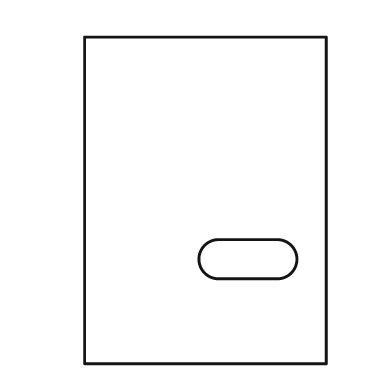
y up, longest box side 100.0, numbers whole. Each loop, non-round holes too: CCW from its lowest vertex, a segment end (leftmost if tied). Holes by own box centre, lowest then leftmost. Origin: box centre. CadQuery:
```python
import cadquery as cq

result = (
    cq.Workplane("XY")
    .moveTo(-37.0, -50.0)
    .lineTo(37.0, -50.0)
    .lineTo(37.0, 50.0)
    .lineTo(-37.0, 50.0)
    .close()
    .moveTo(4.0, -24.0)
    .lineTo(22.0, -24.0)
    .threePointArc((28.0, -18.0), (22.0, -12.0))
    .lineTo(4.0, -12.0)
    .threePointArc((-2.0, -18.0), (4.0, -24.0))
    .close()
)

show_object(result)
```